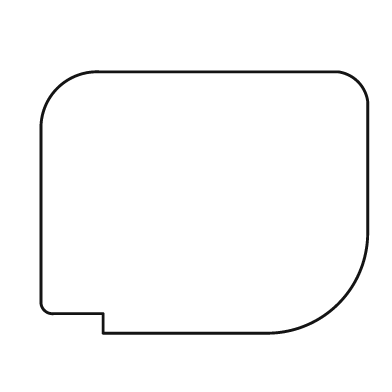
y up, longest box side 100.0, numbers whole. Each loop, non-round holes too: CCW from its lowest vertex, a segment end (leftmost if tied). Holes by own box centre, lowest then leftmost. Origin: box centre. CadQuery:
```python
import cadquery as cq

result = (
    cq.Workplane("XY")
    .moveTo(-31.0, -40.0)
    .lineTo(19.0, -40.0)
    .threePointArc((41.0, -31.0), (50.0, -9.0))
    .lineTo(50.0, 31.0)
    .threePointArc((47.0, 37.0), (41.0, 40.0))
    .lineTo(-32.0, 40.0)
    .threePointArc((-45.0, 35.0), (-50.0, 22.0))
    .lineTo(-50.0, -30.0)
    .threePointArc((-49.0, -33.0), (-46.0, -34.0))
    .lineTo(-31.0, -34.0)
    .close()
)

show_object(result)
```